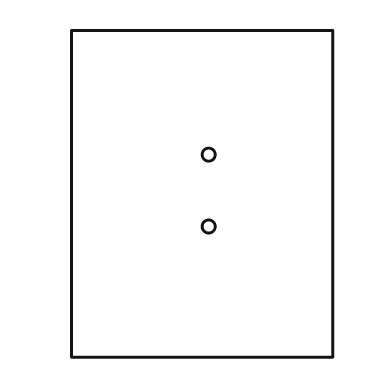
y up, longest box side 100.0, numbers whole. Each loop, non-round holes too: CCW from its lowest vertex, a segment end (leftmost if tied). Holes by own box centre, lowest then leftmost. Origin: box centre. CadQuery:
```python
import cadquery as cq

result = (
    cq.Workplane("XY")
    .moveTo(-40.0, -50.0)
    .lineTo(40.0, -50.0)
    .lineTo(40.0, 50.0)
    .lineTo(-40.0, 50.0)
    .close()
    .moveTo(2.0, -10.0)
    .circle(2.0)
    .moveTo(2.0, 12.0)
    .circle(2.0)
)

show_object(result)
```